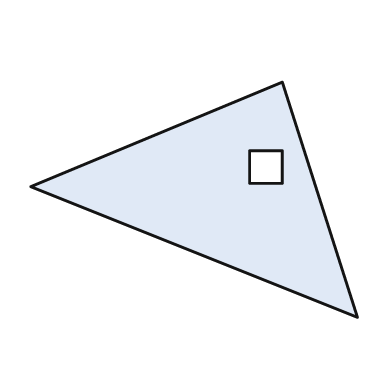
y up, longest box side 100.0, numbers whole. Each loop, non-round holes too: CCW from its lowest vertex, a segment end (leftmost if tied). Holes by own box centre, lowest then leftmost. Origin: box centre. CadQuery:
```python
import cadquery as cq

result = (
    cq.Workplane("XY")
    .moveTo(50.0, -36.0)
    .lineTo(27.0, 36.0)
    .lineTo(-50.0, 4.0)
    .close()
    .moveTo(17.0, 5.0)
    .lineTo(27.0, 5.0)
    .lineTo(27.0, 15.0)
    .lineTo(17.0, 15.0)
    .close()
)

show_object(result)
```